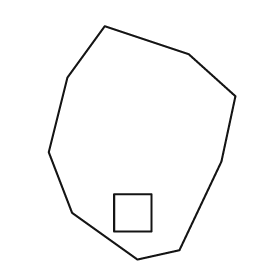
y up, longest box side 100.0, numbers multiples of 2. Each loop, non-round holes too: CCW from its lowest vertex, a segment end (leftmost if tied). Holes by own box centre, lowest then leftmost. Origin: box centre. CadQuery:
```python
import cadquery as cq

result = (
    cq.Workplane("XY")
    .moveTo(-2.0, -50.0)
    .lineTo(16.0, -46.0)
    .lineTo(34.0, -8.0)
    .lineTo(40.0, 20.0)
    .lineTo(20.0, 38.0)
    .lineTo(-16.0, 50.0)
    .lineTo(-32.0, 28.0)
    .lineTo(-40.0, -4.0)
    .lineTo(-30.0, -30.0)
    .close()
    .moveTo(-12.0, -38.0)
    .lineTo(4.0, -38.0)
    .lineTo(4.0, -22.0)
    .lineTo(-12.0, -22.0)
    .close()
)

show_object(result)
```